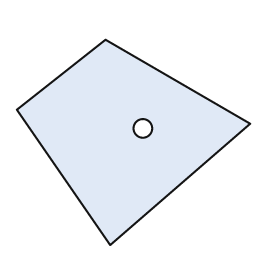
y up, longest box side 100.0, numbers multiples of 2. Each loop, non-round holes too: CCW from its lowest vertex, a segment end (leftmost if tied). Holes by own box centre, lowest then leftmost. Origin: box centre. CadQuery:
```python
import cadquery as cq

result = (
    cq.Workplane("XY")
    .moveTo(-10.0, -44.0)
    .lineTo(50.0, 8.0)
    .lineTo(-12.0, 44.0)
    .lineTo(-50.0, 14.0)
    .close()
    .moveTo(4.0, 6.0)
    .circle(4.0)
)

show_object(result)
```